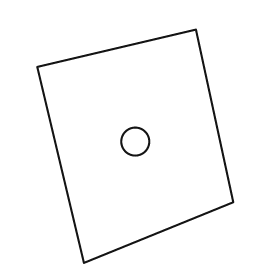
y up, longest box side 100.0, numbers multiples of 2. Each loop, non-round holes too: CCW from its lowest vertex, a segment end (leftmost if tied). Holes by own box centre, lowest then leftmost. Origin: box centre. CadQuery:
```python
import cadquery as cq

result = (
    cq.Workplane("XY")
    .moveTo(-22.0, -50.0)
    .lineTo(42.0, -24.0)
    .lineTo(26.0, 50.0)
    .lineTo(-42.0, 34.0)
    .close()
    .moveTo(0.0, 2.0)
    .circle(6.0)
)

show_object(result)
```